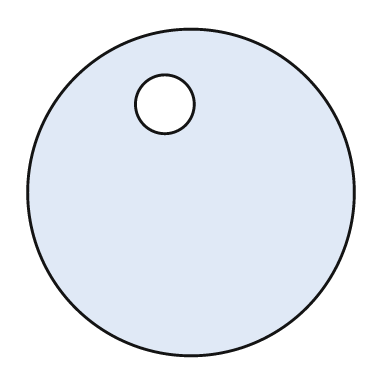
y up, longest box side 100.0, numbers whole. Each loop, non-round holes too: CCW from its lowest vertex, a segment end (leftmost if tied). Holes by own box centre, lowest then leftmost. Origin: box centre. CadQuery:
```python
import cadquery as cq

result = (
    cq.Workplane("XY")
    .moveTo(0.0, 0.0)
    .circle(50.0)
    .moveTo(-8.0, 27.0)
    .circle(9.0)
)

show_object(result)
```